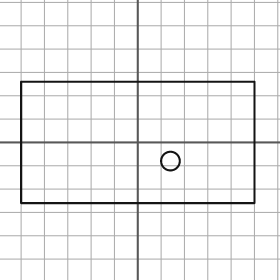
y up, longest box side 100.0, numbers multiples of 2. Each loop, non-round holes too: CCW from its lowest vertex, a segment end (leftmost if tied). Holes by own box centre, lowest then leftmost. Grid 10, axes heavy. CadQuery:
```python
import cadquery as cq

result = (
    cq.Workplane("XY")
    .moveTo(-50.0, -26.0)
    .lineTo(50.0, -26.0)
    .lineTo(50.0, 26.0)
    .lineTo(-50.0, 26.0)
    .close()
    .moveTo(14.0, -8.0)
    .circle(4.0)
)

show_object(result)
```